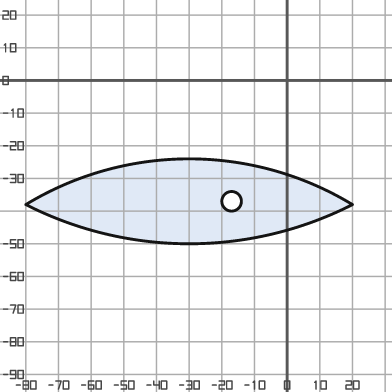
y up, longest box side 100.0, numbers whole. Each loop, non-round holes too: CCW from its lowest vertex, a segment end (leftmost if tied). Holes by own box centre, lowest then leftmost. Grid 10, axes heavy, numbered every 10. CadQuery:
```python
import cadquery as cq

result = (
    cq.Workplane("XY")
    .moveTo(-80.0, -38.0)
    .threePointArc((-30.0, -50.0), (20.0, -38.0))
    .threePointArc((-30.0, -24.0), (-80.0, -38.0))
    .close()
    .moveTo(-17.0, -37.0)
    .circle(3.0)
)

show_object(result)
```